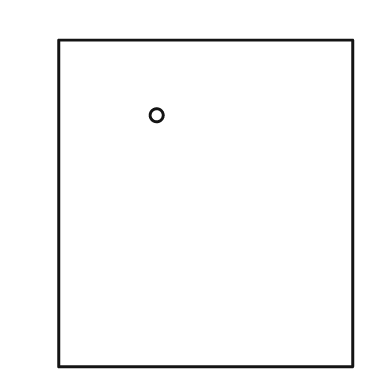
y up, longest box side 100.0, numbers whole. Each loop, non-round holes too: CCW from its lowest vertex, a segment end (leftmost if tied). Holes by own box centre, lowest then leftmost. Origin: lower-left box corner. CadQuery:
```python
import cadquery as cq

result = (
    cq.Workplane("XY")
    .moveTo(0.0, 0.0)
    .lineTo(90.0, 0.0)
    .lineTo(90.0, 100.0)
    .lineTo(0.0, 100.0)
    .close()
    .moveTo(30.0, 77.0)
    .circle(2.0)
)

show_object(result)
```